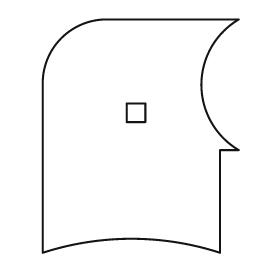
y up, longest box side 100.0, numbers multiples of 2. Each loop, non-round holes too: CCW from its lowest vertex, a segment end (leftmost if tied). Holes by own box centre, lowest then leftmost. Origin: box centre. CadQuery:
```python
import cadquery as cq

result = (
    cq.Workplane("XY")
    .moveTo(-42.0, -50.0)
    .threePointArc((-4.0, -44.0), (34.0, -50.0))
    .lineTo(34.0, -6.0)
    .lineTo(42.0, -6.0)
    .threePointArc((26.0, 22.0), (42.0, 50.0))
    .lineTo(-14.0, 50.0)
    .threePointArc((-34.0, 42.0), (-42.0, 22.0))
    .close()
    .moveTo(-6.0, 6.0)
    .lineTo(2.0, 6.0)
    .lineTo(2.0, 14.0)
    .lineTo(-6.0, 14.0)
    .close()
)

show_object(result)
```